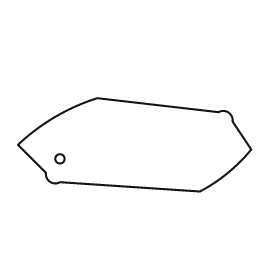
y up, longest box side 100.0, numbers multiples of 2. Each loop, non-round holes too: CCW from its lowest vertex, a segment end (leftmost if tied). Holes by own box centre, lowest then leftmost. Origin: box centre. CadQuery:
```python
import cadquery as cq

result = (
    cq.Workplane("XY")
    .moveTo(28.0, -20.0)
    .threePointArc((40.0, -12.0), (50.0, -2.0))
    .lineTo(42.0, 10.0)
    .threePointArc((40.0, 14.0), (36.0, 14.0))
    .lineTo(-16.0, 20.0)
    .threePointArc((-34.0, 12.0), (-50.0, 0.0))
    .lineTo(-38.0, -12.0)
    .threePointArc((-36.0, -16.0), (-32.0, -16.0))
    .close()
    .moveTo(-32.0, -6.0)
    .circle(2.0)
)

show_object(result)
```